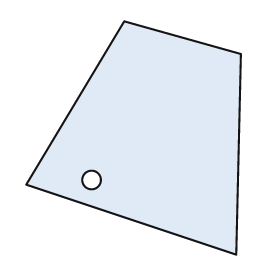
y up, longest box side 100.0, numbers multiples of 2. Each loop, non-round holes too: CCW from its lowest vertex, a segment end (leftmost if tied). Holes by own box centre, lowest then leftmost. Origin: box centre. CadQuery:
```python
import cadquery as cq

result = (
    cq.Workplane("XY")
    .moveTo(44.0, -50.0)
    .lineTo(46.0, 36.0)
    .lineTo(-4.0, 50.0)
    .lineTo(-46.0, -20.0)
    .close()
    .moveTo(-18.0, -18.0)
    .circle(4.0)
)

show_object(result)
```